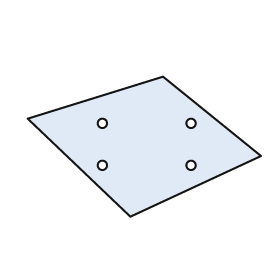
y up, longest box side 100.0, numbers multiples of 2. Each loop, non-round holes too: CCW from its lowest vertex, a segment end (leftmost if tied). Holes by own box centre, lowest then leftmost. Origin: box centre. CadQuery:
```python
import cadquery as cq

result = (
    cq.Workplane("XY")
    .moveTo(-6.0, -30.0)
    .lineTo(50.0, -4.0)
    .lineTo(8.0, 30.0)
    .lineTo(-50.0, 12.0)
    .close()
    .moveTo(-18.0, -8.0)
    .circle(2.0)
    .moveTo(20.0, -8.0)
    .circle(2.0)
    .moveTo(-18.0, 10.0)
    .circle(2.0)
    .moveTo(20.0, 10.0)
    .circle(2.0)
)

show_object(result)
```